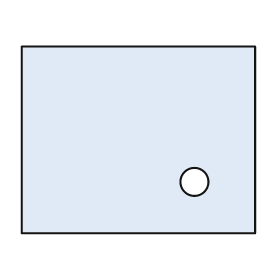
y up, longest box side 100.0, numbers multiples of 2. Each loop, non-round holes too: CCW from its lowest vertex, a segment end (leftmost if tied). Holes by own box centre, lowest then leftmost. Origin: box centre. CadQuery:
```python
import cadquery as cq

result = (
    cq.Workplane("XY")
    .moveTo(-50.0, -40.0)
    .lineTo(50.0, -40.0)
    .lineTo(50.0, 40.0)
    .lineTo(-50.0, 40.0)
    .close()
    .moveTo(24.0, -18.0)
    .circle(6.0)
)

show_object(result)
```